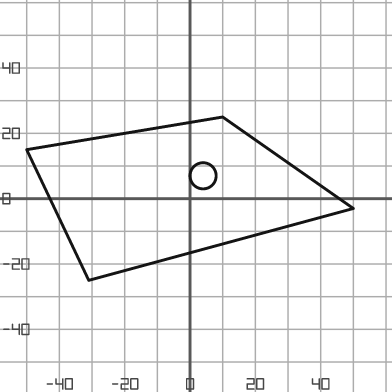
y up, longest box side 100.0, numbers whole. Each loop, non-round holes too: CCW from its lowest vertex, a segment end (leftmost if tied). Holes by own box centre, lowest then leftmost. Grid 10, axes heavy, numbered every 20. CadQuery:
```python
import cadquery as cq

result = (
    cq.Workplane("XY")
    .moveTo(-31.0, -25.0)
    .lineTo(50.0, -3.0)
    .lineTo(10.0, 25.0)
    .lineTo(-50.0, 15.0)
    .close()
    .moveTo(4.0, 7.0)
    .circle(4.0)
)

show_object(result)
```